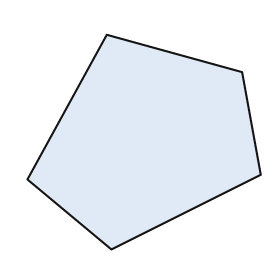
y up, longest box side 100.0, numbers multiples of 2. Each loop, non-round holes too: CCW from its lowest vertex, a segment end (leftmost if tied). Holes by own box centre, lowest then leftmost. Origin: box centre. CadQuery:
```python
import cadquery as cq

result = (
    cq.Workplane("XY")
    .moveTo(-14.0, -46.0)
    .lineTo(50.0, -14.0)
    .lineTo(42.0, 30.0)
    .lineTo(-16.0, 46.0)
    .lineTo(-50.0, -16.0)
    .close()
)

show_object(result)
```